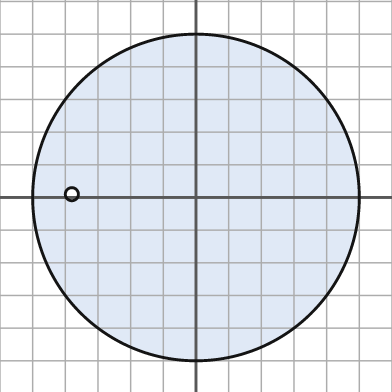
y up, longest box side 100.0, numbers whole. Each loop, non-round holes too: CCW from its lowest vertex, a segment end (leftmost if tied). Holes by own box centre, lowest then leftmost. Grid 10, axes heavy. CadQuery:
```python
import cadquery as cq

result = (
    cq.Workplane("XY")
    .moveTo(0.0, 0.0)
    .circle(50.0)
    .moveTo(-38.0, 1.0)
    .circle(2.0)
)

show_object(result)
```